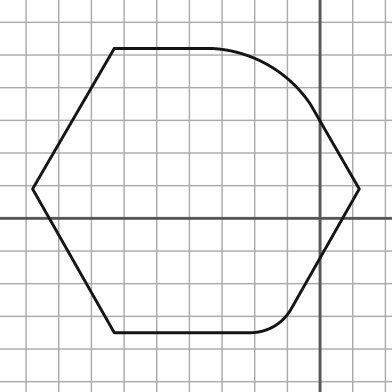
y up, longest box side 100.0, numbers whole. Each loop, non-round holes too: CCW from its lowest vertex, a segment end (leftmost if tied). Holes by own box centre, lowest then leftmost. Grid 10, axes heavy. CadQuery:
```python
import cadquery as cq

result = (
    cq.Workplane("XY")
    .moveTo(-63.0, -35.0)
    .lineTo(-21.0, -35.0)
    .threePointArc((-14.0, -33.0), (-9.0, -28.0))
    .lineTo(12.0, 9.0)
    .lineTo(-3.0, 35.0)
    .threePointArc((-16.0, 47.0), (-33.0, 52.0))
    .lineTo(-63.0, 52.0)
    .lineTo(-88.0, 9.0)
    .close()
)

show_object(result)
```